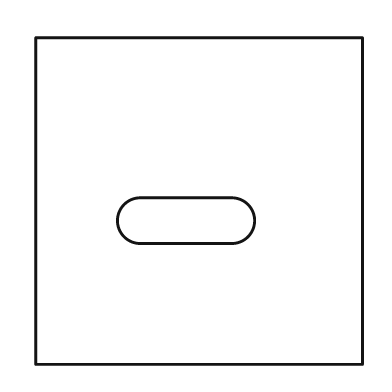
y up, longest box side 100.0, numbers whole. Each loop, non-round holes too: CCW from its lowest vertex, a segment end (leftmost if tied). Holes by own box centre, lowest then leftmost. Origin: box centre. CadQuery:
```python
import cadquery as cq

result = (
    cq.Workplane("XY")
    .moveTo(-50.0, -50.0)
    .lineTo(50.0, -50.0)
    .lineTo(50.0, 50.0)
    .lineTo(-50.0, 50.0)
    .close()
    .moveTo(-18.0, -13.0)
    .lineTo(10.0, -13.0)
    .threePointArc((17.0, -6.0), (10.0, 1.0))
    .lineTo(-18.0, 1.0)
    .threePointArc((-25.0, -6.0), (-18.0, -13.0))
    .close()
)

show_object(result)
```